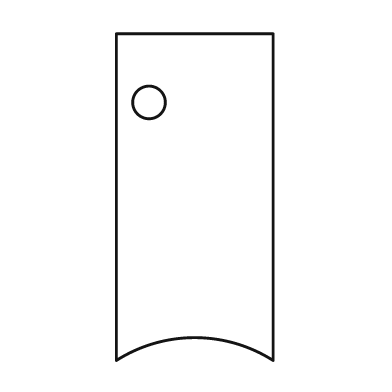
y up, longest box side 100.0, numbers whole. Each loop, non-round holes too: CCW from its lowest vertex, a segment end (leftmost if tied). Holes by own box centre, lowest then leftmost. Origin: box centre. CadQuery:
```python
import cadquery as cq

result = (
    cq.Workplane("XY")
    .moveTo(-24.0, -50.0)
    .threePointArc((0.0, -43.0), (24.0, -50.0))
    .lineTo(24.0, 50.0)
    .lineTo(-24.0, 50.0)
    .close()
    .moveTo(-14.0, 29.0)
    .circle(5.0)
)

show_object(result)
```